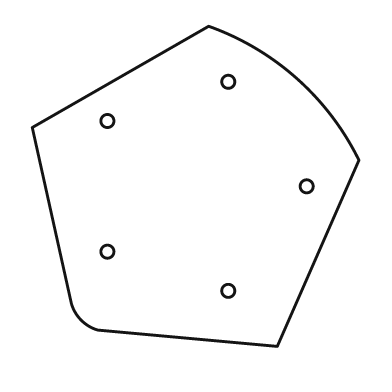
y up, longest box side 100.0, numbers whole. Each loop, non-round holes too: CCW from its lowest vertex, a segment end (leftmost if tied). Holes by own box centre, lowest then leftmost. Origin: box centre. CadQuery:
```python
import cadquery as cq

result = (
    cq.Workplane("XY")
    .moveTo(25.0, -49.0)
    .lineTo(50.0, 8.0)
    .threePointArc((31.0, 33.0), (4.0, 49.0))
    .lineTo(-50.0, 18.0)
    .lineTo(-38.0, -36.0)
    .threePointArc((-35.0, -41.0), (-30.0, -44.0))
    .close()
    .moveTo(10.0, -32.0)
    .circle(2.0)
    .moveTo(-27.0, -20.0)
    .circle(2.0)
    .moveTo(34.0, 0.0)
    .circle(2.0)
    .moveTo(-27.0, 20.0)
    .circle(2.0)
    .moveTo(10.0, 32.0)
    .circle(2.0)
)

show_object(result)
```